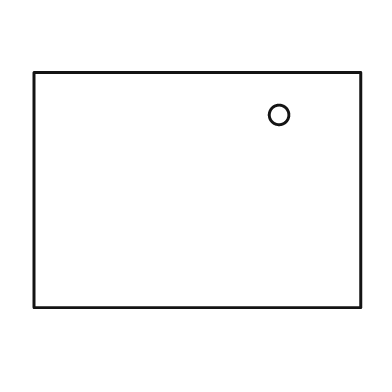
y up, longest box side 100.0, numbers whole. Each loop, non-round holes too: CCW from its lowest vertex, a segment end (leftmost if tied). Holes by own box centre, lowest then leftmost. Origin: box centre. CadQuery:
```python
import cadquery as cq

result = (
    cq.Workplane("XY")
    .moveTo(-50.0, -36.0)
    .lineTo(50.0, -36.0)
    .lineTo(50.0, 36.0)
    .lineTo(-50.0, 36.0)
    .close()
    .moveTo(25.0, 23.0)
    .circle(3.0)
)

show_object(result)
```